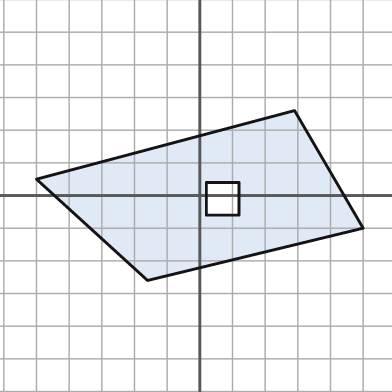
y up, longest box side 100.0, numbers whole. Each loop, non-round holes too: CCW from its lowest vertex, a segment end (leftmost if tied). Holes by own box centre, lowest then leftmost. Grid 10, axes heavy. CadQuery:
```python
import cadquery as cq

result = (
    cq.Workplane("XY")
    .moveTo(-16.0, -26.0)
    .lineTo(50.0, -10.0)
    .lineTo(29.0, 26.0)
    .lineTo(-50.0, 5.0)
    .close()
    .moveTo(2.0, -6.0)
    .lineTo(12.0, -6.0)
    .lineTo(12.0, 4.0)
    .lineTo(2.0, 4.0)
    .close()
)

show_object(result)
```